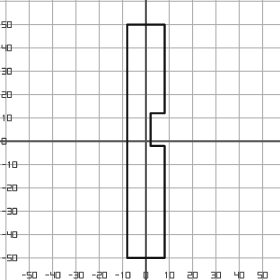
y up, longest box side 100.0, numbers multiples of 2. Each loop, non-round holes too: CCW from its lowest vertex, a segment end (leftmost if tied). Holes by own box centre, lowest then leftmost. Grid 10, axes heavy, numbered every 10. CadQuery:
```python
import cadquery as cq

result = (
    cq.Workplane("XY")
    .moveTo(-8.0, -50.0)
    .lineTo(8.0, -50.0)
    .lineTo(8.0, -2.0)
    .lineTo(2.0, -2.0)
    .lineTo(2.0, 12.0)
    .lineTo(8.0, 12.0)
    .lineTo(8.0, 50.0)
    .lineTo(-8.0, 50.0)
    .close()
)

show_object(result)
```